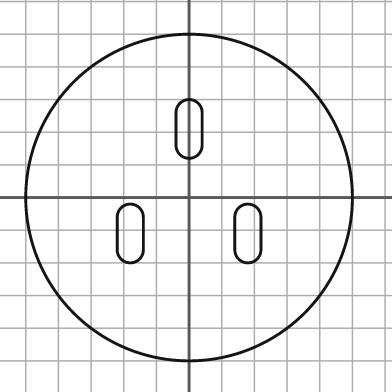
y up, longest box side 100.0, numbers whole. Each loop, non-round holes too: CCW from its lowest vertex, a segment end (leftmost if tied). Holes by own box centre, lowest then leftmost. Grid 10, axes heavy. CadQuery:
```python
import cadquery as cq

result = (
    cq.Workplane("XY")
    .moveTo(0.0, 0.0)
    .circle(50.0)
    .moveTo(-22.0, -16.0)
    .threePointArc((-18.0, -20.0), (-14.0, -16.0))
    .lineTo(-14.0, -6.0)
    .threePointArc((-18.0, -2.0), (-22.0, -6.0))
    .close()
    .moveTo(14.0, -16.0)
    .threePointArc((18.0, -20.0), (22.0, -16.0))
    .lineTo(22.0, -6.0)
    .threePointArc((18.0, -2.0), (14.0, -6.0))
    .close()
    .moveTo(-4.0, 16.0)
    .threePointArc((0.0, 12.0), (4.0, 16.0))
    .lineTo(4.0, 26.0)
    .threePointArc((0.0, 30.0), (-4.0, 26.0))
    .close()
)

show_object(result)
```